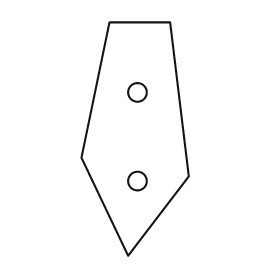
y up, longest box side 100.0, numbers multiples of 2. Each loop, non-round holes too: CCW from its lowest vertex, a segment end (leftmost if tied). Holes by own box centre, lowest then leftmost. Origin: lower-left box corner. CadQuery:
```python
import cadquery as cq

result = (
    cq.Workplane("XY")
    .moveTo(20.0, 0.0)
    .lineTo(46.0, 34.0)
    .lineTo(38.0, 100.0)
    .lineTo(12.0, 100.0)
    .lineTo(0.0, 42.0)
    .close()
    .moveTo(24.0, 32.0)
    .circle(4.0)
    .moveTo(24.0, 70.0)
    .circle(4.0)
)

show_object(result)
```